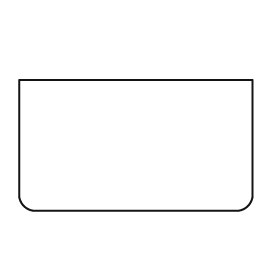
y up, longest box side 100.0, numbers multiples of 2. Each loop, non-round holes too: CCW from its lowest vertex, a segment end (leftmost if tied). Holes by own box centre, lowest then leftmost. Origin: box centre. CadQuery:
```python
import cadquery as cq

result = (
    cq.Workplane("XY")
    .moveTo(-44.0, -28.0)
    .lineTo(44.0, -28.0)
    .threePointArc((48.0, -26.0), (50.0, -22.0))
    .lineTo(50.0, 28.0)
    .lineTo(-50.0, 28.0)
    .lineTo(-50.0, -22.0)
    .threePointArc((-48.0, -26.0), (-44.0, -28.0))
    .close()
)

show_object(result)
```